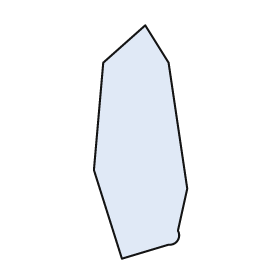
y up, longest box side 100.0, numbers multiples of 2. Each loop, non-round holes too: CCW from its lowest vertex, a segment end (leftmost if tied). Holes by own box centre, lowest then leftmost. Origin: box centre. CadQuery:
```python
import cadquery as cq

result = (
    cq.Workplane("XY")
    .moveTo(-8.0, -50.0)
    .lineTo(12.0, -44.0)
    .threePointArc((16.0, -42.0), (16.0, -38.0))
    .lineTo(20.0, -20.0)
    .lineTo(12.0, 34.0)
    .lineTo(2.0, 50.0)
    .lineTo(-16.0, 34.0)
    .lineTo(-20.0, -12.0)
    .close()
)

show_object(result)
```